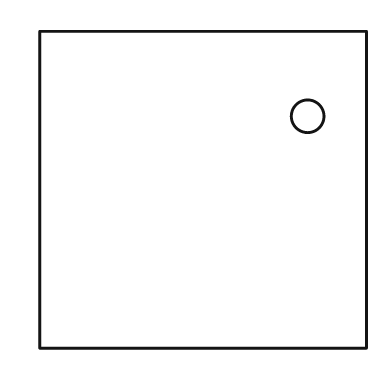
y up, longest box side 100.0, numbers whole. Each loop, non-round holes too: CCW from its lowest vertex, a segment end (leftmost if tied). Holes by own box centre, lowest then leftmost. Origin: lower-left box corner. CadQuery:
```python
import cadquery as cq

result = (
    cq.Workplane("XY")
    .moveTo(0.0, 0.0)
    .lineTo(100.0, 0.0)
    .lineTo(100.0, 97.0)
    .lineTo(0.0, 97.0)
    .close()
    .moveTo(82.0, 71.0)
    .circle(5.0)
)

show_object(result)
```